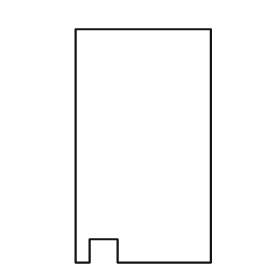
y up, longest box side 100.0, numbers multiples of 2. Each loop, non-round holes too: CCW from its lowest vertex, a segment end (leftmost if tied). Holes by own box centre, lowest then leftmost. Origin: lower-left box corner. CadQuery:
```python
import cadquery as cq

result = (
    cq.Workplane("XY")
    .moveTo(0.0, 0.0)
    .lineTo(6.0, 0.0)
    .lineTo(6.0, 10.0)
    .lineTo(18.0, 10.0)
    .lineTo(18.0, 0.0)
    .lineTo(58.0, 0.0)
    .lineTo(58.0, 100.0)
    .lineTo(0.0, 100.0)
    .close()
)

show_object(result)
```